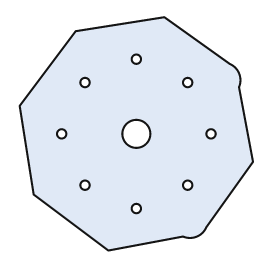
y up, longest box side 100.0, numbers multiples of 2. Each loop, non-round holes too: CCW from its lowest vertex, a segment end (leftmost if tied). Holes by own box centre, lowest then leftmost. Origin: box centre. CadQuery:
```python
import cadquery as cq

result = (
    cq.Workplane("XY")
    .moveTo(-12.0, -50.0)
    .lineTo(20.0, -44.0)
    .threePointArc((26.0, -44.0), (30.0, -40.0))
    .lineTo(50.0, -12.0)
    .lineTo(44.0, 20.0)
    .threePointArc((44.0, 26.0), (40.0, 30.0))
    .lineTo(12.0, 50.0)
    .lineTo(-26.0, 44.0)
    .lineTo(-50.0, 12.0)
    .lineTo(-44.0, -26.0)
    .close()
    .moveTo(0.0, -32.0)
    .circle(2.0)
    .moveTo(-22.0, -22.0)
    .circle(2.0)
    .moveTo(22.0, -22.0)
    .circle(2.0)
    .moveTo(-32.0, 0.0)
    .circle(2.0)
    .moveTo(0.0, 0.0)
    .circle(6.0)
    .moveTo(32.0, 0.0)
    .circle(2.0)
    .moveTo(-22.0, 22.0)
    .circle(2.0)
    .moveTo(22.0, 22.0)
    .circle(2.0)
    .moveTo(0.0, 32.0)
    .circle(2.0)
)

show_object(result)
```